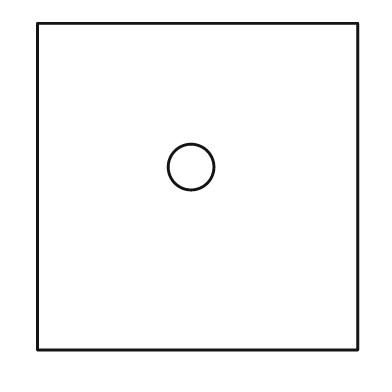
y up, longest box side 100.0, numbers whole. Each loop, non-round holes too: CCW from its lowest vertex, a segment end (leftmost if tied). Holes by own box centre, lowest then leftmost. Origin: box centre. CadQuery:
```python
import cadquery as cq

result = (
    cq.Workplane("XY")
    .moveTo(-49.0, -50.0)
    .lineTo(49.0, -50.0)
    .lineTo(49.0, 50.0)
    .lineTo(-49.0, 50.0)
    .close()
    .moveTo(-2.0, 6.0)
    .circle(7.0)
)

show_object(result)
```